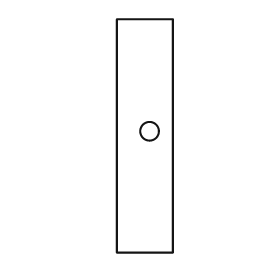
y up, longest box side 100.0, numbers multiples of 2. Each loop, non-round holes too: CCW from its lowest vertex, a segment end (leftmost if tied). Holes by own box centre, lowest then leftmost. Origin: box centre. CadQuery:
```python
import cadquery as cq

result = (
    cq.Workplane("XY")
    .moveTo(-12.0, -50.0)
    .lineTo(12.0, -50.0)
    .lineTo(12.0, 50.0)
    .lineTo(-12.0, 50.0)
    .close()
    .moveTo(2.0, 2.0)
    .circle(4.0)
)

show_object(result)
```